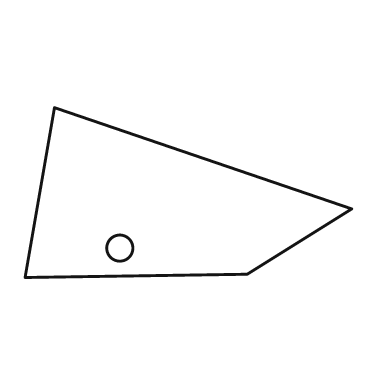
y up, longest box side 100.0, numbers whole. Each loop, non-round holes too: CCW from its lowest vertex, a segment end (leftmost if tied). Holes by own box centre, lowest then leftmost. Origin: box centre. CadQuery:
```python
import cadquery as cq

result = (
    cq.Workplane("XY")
    .moveTo(-50.0, -26.0)
    .lineTo(18.0, -25.0)
    .lineTo(50.0, -5.0)
    .lineTo(-41.0, 26.0)
    .close()
    .moveTo(-21.0, -17.0)
    .circle(4.0)
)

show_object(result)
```